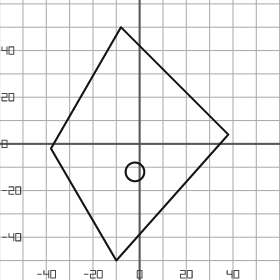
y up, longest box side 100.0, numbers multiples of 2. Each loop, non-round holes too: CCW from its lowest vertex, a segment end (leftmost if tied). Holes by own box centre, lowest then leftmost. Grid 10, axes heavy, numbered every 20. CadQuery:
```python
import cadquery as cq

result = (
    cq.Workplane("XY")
    .moveTo(-10.0, -50.0)
    .lineTo(38.0, 4.0)
    .lineTo(-8.0, 50.0)
    .lineTo(-38.0, -2.0)
    .close()
    .moveTo(-2.0, -12.0)
    .circle(4.0)
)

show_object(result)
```